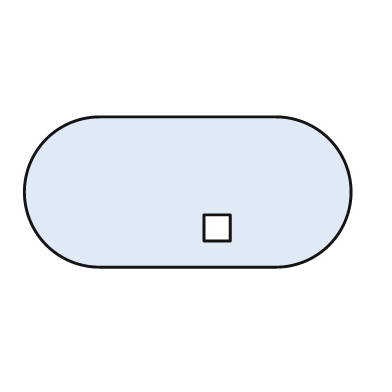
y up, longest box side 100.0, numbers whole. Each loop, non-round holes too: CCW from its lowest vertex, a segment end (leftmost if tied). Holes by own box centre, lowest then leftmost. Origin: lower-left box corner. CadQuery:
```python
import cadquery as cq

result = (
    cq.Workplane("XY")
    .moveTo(23.0, 0.0)
    .lineTo(77.0, 0.0)
    .threePointArc((100.0, 23.0), (77.0, 46.0))
    .lineTo(23.0, 46.0)
    .threePointArc((0.0, 23.0), (23.0, 0.0))
    .close()
    .moveTo(55.0, 8.0)
    .lineTo(63.0, 8.0)
    .lineTo(63.0, 16.0)
    .lineTo(55.0, 16.0)
    .close()
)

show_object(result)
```